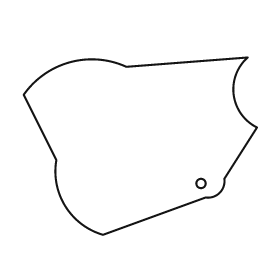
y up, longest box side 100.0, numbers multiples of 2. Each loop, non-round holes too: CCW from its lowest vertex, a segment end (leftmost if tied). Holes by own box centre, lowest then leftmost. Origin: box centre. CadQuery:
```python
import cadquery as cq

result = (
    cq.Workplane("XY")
    .moveTo(-16.0, -38.0)
    .lineTo(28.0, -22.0)
    .threePointArc((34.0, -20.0), (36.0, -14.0))
    .lineTo(50.0, 8.0)
    .threePointArc((40.0, 22.0), (46.0, 38.0))
    .lineTo(-6.0, 34.0)
    .threePointArc((-30.0, 36.0), (-50.0, 22.0))
    .lineTo(-36.0, -6.0)
    .threePointArc((-32.0, -26.0), (-16.0, -38.0))
    .close()
    .moveTo(26.0, -16.0)
    .circle(2.0)
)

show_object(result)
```